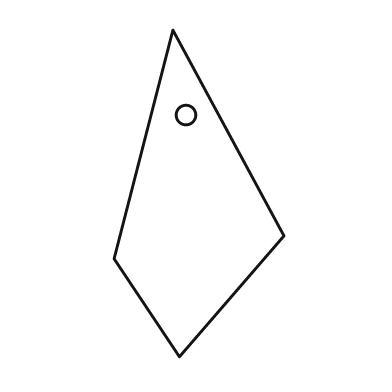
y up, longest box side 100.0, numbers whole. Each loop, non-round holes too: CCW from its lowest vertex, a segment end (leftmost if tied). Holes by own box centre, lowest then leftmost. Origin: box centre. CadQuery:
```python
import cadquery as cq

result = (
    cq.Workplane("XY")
    .moveTo(-6.0, -50.0)
    .lineTo(26.0, -13.0)
    .lineTo(-8.0, 50.0)
    .lineTo(-26.0, -20.0)
    .close()
    .moveTo(-4.0, 24.0)
    .circle(3.0)
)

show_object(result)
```